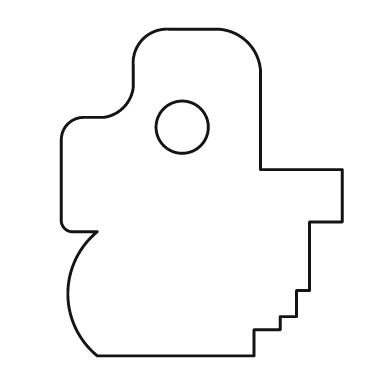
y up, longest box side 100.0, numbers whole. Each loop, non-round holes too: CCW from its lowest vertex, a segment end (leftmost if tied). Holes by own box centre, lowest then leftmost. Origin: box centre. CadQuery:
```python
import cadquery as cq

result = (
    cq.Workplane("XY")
    .moveTo(-32.0, -50.0)
    .lineTo(16.0, -50.0)
    .lineTo(16.0, -42.0)
    .lineTo(24.0, -42.0)
    .lineTo(24.0, -38.0)
    .lineTo(29.0, -38.0)
    .lineTo(29.0, -30.0)
    .lineTo(33.0, -30.0)
    .lineTo(33.0, -9.0)
    .lineTo(43.0, -9.0)
    .lineTo(43.0, 7.0)
    .lineTo(18.0, 7.0)
    .lineTo(18.0, 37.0)
    .threePointArc((14.0, 46.0), (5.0, 50.0))
    .lineTo(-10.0, 50.0)
    .threePointArc((-18.0, 47.0), (-21.0, 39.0))
    .lineTo(-21.0, 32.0)
    .threePointArc((-24.0, 26.0), (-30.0, 23.0))
    .lineTo(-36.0, 23.0)
    .threePointArc((-41.0, 21.0), (-43.0, 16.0))
    .lineTo(-43.0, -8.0)
    .threePointArc((-42.0, -11.0), (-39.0, -12.0))
    .lineTo(-32.0, -12.0)
    .threePointArc((-41.0, -31.0), (-32.0, -50.0))
    .close()
    .moveTo(-6.0, 20.0)
    .circle(8.0)
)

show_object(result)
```